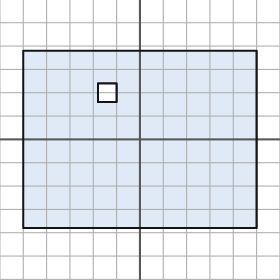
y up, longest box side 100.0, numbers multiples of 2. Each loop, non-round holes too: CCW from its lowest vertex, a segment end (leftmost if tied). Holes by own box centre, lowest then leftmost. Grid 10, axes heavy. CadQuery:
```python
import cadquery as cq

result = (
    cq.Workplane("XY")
    .moveTo(-50.0, -38.0)
    .lineTo(50.0, -38.0)
    .lineTo(50.0, 38.0)
    .lineTo(-50.0, 38.0)
    .close()
    .moveTo(-18.0, 16.0)
    .lineTo(-10.0, 16.0)
    .lineTo(-10.0, 24.0)
    .lineTo(-18.0, 24.0)
    .close()
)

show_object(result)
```